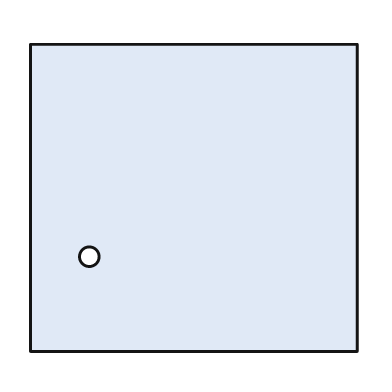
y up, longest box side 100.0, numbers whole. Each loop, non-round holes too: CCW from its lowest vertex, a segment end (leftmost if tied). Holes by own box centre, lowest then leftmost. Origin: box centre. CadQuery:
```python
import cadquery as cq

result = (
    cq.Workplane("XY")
    .moveTo(-50.0, -47.0)
    .lineTo(50.0, -47.0)
    .lineTo(50.0, 47.0)
    .lineTo(-50.0, 47.0)
    .close()
    .moveTo(-32.0, -18.0)
    .circle(3.0)
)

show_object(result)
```